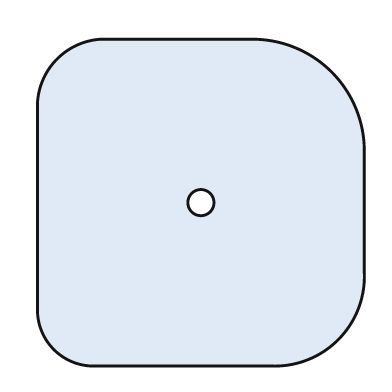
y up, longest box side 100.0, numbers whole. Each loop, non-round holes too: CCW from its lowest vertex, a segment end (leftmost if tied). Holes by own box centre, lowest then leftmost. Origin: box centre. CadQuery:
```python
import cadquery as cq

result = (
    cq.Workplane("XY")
    .moveTo(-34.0, -50.0)
    .lineTo(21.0, -50.0)
    .threePointArc((42.0, -42.0), (50.0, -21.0))
    .lineTo(50.0, 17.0)
    .threePointArc((40.0, 40.0), (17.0, 50.0))
    .lineTo(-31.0, 50.0)
    .threePointArc((-44.0, 44.0), (-50.0, 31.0))
    .lineTo(-50.0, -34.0)
    .threePointArc((-45.0, -45.0), (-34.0, -50.0))
    .close()
    .moveTo(0.0, 0.0)
    .circle(4.0)
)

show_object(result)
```